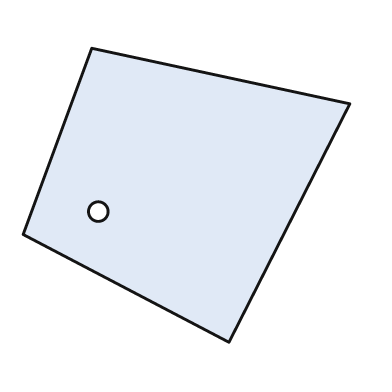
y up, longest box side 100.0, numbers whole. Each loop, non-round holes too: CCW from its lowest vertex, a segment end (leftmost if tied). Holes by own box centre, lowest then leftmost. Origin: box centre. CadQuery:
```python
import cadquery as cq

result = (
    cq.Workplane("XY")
    .moveTo(13.0, -45.0)
    .lineTo(50.0, 28.0)
    .lineTo(-29.0, 45.0)
    .lineTo(-50.0, -12.0)
    .close()
    .moveTo(-27.0, -5.0)
    .circle(3.0)
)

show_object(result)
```